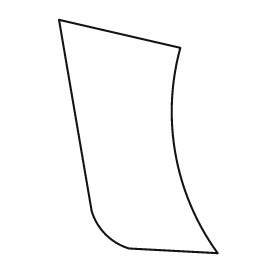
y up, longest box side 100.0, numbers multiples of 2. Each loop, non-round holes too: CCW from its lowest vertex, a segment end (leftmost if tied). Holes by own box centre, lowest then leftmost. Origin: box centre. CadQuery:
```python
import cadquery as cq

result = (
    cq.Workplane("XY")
    .moveTo(34.0, -50.0)
    .threePointArc((16.0, -8.0), (18.0, 38.0))
    .lineTo(-34.0, 50.0)
    .lineTo(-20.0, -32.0)
    .threePointArc((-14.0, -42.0), (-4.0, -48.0))
    .close()
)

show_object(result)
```